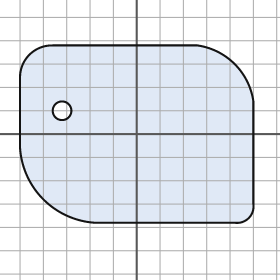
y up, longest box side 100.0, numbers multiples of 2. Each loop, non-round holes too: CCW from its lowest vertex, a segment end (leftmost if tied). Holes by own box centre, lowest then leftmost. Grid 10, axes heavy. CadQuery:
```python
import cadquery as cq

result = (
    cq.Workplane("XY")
    .moveTo(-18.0, -38.0)
    .lineTo(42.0, -38.0)
    .threePointArc((48.0, -36.0), (50.0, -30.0))
    .lineTo(50.0, 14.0)
    .threePointArc((42.0, 30.0), (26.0, 38.0))
    .lineTo(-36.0, 38.0)
    .threePointArc((-46.0, 34.0), (-50.0, 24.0))
    .lineTo(-50.0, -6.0)
    .threePointArc((-40.0, -28.0), (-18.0, -38.0))
    .close()
    .moveTo(-32.0, 10.0)
    .circle(4.0)
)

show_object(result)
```